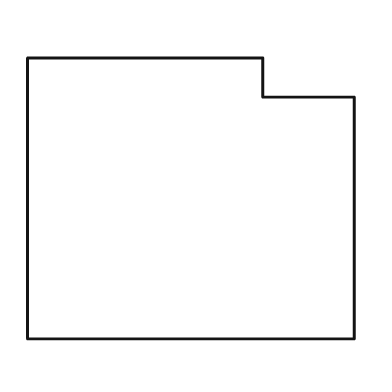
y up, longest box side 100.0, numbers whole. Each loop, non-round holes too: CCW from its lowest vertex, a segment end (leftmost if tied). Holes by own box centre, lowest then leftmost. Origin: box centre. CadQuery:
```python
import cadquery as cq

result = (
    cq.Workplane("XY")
    .moveTo(-50.0, -43.0)
    .lineTo(50.0, -43.0)
    .lineTo(50.0, 31.0)
    .lineTo(22.0, 31.0)
    .lineTo(22.0, 43.0)
    .lineTo(-50.0, 43.0)
    .close()
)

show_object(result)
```